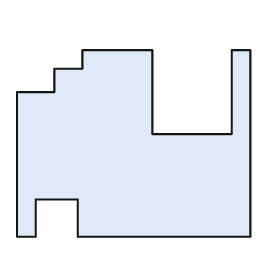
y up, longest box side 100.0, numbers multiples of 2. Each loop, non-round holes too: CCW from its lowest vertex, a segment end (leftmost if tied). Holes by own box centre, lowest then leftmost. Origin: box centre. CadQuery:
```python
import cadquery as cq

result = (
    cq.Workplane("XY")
    .moveTo(-50.0, -40.0)
    .lineTo(-42.0, -40.0)
    .lineTo(-42.0, -24.0)
    .lineTo(-24.0, -24.0)
    .lineTo(-24.0, -40.0)
    .lineTo(50.0, -40.0)
    .lineTo(50.0, 40.0)
    .lineTo(42.0, 40.0)
    .lineTo(42.0, 4.0)
    .lineTo(8.0, 4.0)
    .lineTo(8.0, 40.0)
    .lineTo(-22.0, 40.0)
    .lineTo(-22.0, 32.0)
    .lineTo(-34.0, 32.0)
    .lineTo(-34.0, 22.0)
    .lineTo(-50.0, 22.0)
    .close()
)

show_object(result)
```